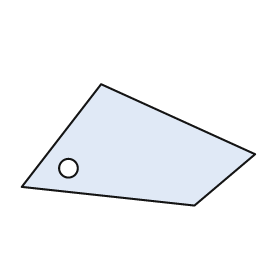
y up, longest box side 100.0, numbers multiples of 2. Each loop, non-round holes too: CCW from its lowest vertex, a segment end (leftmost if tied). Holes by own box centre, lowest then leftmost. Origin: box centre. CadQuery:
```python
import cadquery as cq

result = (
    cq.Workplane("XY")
    .moveTo(24.0, -26.0)
    .lineTo(50.0, -4.0)
    .lineTo(-16.0, 26.0)
    .lineTo(-50.0, -18.0)
    .close()
    .moveTo(-30.0, -10.0)
    .circle(4.0)
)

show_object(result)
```